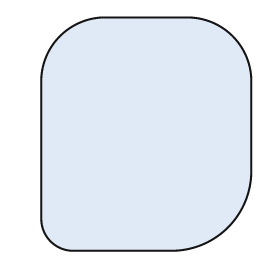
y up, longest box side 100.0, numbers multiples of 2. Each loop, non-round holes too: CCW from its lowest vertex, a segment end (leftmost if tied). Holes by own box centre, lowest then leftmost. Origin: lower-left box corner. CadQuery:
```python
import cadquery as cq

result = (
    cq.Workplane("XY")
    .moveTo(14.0, 0.0)
    .lineTo(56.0, 0.0)
    .threePointArc((80.0, 10.0), (90.0, 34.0))
    .lineTo(90.0, 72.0)
    .threePointArc((82.0, 92.0), (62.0, 100.0))
    .lineTo(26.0, 100.0)
    .threePointArc((8.0, 92.0), (0.0, 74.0))
    .lineTo(0.0, 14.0)
    .threePointArc((4.0, 4.0), (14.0, 0.0))
    .close()
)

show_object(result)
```